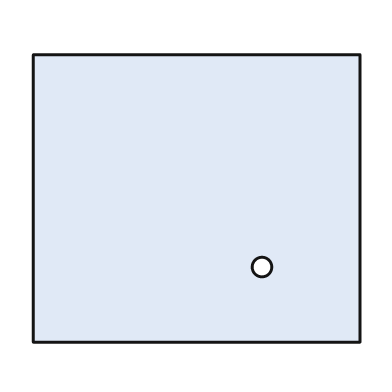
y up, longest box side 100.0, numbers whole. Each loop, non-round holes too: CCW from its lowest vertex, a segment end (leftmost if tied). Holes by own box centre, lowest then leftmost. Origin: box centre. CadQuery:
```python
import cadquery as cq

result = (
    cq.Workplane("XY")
    .moveTo(-50.0, -44.0)
    .lineTo(50.0, -44.0)
    .lineTo(50.0, 44.0)
    .lineTo(-50.0, 44.0)
    .close()
    .moveTo(20.0, -21.0)
    .circle(3.0)
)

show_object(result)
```